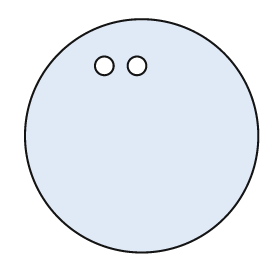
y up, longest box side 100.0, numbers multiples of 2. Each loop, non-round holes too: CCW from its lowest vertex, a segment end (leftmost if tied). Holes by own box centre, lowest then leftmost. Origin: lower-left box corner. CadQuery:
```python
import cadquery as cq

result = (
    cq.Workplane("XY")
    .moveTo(50.0, 50.0)
    .circle(50.0)
    .moveTo(34.0, 80.0)
    .circle(4.0)
    .moveTo(48.0, 80.0)
    .circle(4.0)
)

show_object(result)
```